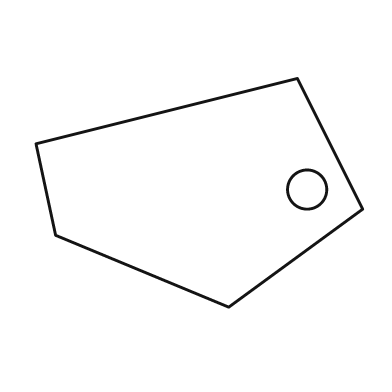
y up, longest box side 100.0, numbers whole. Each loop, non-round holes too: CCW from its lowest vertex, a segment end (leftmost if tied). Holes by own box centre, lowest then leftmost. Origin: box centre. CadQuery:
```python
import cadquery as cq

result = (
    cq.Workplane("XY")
    .moveTo(9.0, -35.0)
    .lineTo(50.0, -5.0)
    .lineTo(30.0, 35.0)
    .lineTo(-50.0, 15.0)
    .lineTo(-44.0, -13.0)
    .close()
    .moveTo(33.0, 1.0)
    .circle(6.0)
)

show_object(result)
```